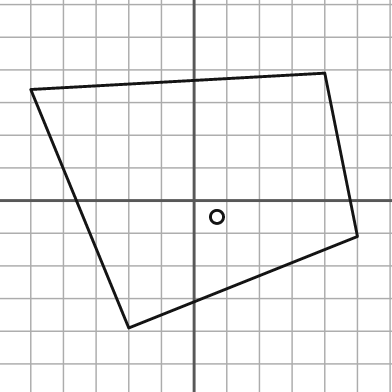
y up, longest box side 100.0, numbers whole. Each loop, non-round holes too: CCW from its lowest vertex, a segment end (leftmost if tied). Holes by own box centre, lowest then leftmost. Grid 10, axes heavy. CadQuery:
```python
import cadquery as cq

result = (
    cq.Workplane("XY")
    .moveTo(-20.0, -39.0)
    .lineTo(50.0, -11.0)
    .lineTo(40.0, 39.0)
    .lineTo(-50.0, 34.0)
    .close()
    .moveTo(7.0, -5.0)
    .circle(2.0)
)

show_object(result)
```